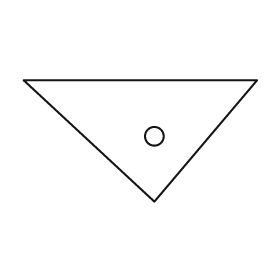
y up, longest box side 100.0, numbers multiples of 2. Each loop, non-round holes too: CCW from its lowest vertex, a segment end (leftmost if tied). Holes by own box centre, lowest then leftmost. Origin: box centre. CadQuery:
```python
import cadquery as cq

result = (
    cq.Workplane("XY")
    .moveTo(6.0, -26.0)
    .lineTo(50.0, 26.0)
    .lineTo(-50.0, 26.0)
    .close()
    .moveTo(6.0, 2.0)
    .circle(4.0)
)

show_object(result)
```